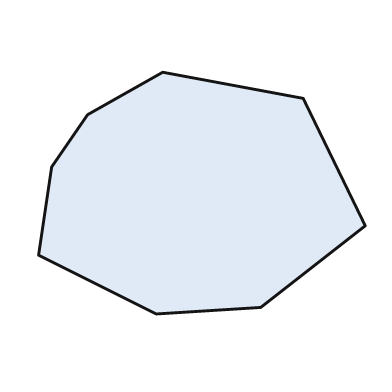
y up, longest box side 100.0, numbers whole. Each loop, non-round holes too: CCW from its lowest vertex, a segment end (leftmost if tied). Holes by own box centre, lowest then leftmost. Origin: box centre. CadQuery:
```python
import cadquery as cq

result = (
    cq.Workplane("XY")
    .moveTo(-14.0, -37.0)
    .lineTo(18.0, -35.0)
    .lineTo(50.0, -10.0)
    .lineTo(31.0, 29.0)
    .lineTo(-12.0, 37.0)
    .lineTo(-35.0, 24.0)
    .lineTo(-46.0, 8.0)
    .lineTo(-50.0, -19.0)
    .close()
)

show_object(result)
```